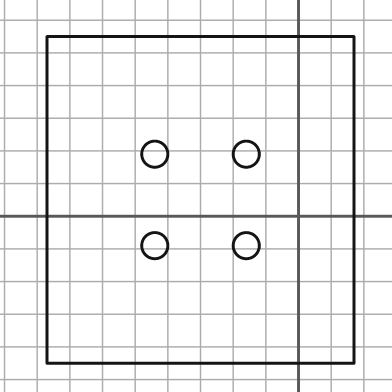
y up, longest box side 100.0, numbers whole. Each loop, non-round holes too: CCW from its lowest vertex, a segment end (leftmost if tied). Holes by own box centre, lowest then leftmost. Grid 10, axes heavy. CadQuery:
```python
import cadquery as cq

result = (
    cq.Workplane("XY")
    .moveTo(-77.0, -45.0)
    .lineTo(17.0, -45.0)
    .lineTo(17.0, 55.0)
    .lineTo(-77.0, 55.0)
    .close()
    .moveTo(-44.0, -9.0)
    .circle(4.0)
    .moveTo(-16.0, -9.0)
    .circle(4.0)
    .moveTo(-44.0, 19.0)
    .circle(4.0)
    .moveTo(-16.0, 19.0)
    .circle(4.0)
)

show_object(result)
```